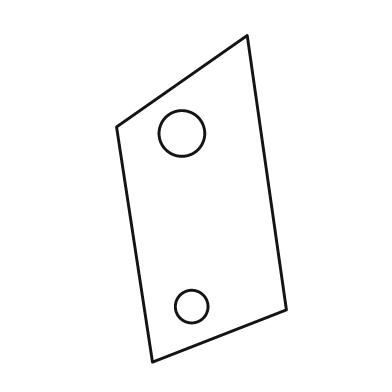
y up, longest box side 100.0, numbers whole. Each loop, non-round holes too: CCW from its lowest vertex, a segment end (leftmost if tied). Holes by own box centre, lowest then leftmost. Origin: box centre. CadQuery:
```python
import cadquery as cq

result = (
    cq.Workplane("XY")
    .moveTo(-15.0, -50.0)
    .lineTo(26.0, -34.0)
    .lineTo(14.0, 50.0)
    .lineTo(-26.0, 22.0)
    .close()
    .moveTo(-3.0, -33.0)
    .circle(5.0)
    .moveTo(-6.0, 20.0)
    .circle(7.0)
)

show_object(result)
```